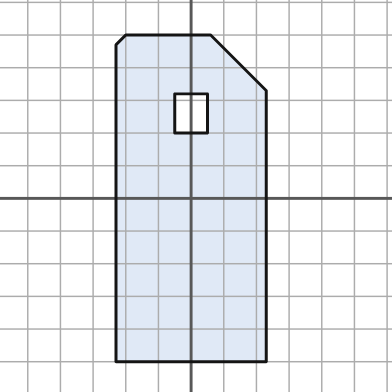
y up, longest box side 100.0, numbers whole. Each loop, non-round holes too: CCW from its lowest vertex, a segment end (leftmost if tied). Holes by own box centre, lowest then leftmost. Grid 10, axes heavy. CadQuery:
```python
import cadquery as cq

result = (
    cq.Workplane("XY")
    .moveTo(-23.0, -50.0)
    .lineTo(23.0, -50.0)
    .lineTo(23.0, 33.0)
    .lineTo(6.0, 50.0)
    .lineTo(-20.0, 50.0)
    .lineTo(-23.0, 47.0)
    .close()
    .moveTo(-5.0, 20.0)
    .lineTo(5.0, 20.0)
    .lineTo(5.0, 32.0)
    .lineTo(-5.0, 32.0)
    .close()
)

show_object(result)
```